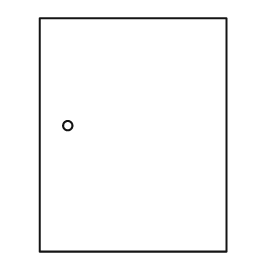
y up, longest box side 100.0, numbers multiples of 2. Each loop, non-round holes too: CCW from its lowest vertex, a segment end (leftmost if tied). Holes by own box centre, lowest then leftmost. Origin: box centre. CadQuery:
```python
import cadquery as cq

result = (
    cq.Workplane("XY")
    .moveTo(-40.0, -50.0)
    .lineTo(40.0, -50.0)
    .lineTo(40.0, 50.0)
    .lineTo(-40.0, 50.0)
    .close()
    .moveTo(-28.0, 4.0)
    .circle(2.0)
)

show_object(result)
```